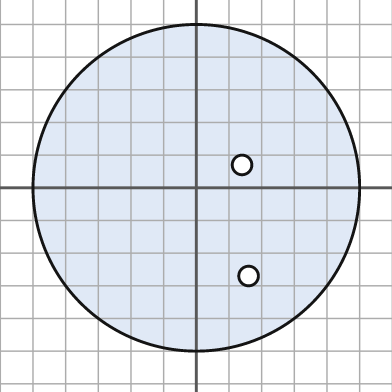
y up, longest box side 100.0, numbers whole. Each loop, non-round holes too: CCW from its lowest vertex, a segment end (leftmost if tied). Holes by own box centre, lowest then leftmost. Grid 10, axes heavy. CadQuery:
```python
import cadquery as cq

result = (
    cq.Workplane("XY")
    .moveTo(0.0, 0.0)
    .circle(50.0)
    .moveTo(16.0, -27.0)
    .circle(3.0)
    .moveTo(14.0, 7.0)
    .circle(3.0)
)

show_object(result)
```